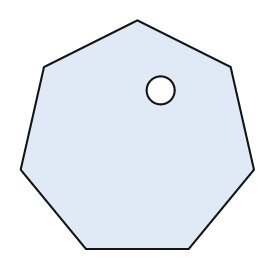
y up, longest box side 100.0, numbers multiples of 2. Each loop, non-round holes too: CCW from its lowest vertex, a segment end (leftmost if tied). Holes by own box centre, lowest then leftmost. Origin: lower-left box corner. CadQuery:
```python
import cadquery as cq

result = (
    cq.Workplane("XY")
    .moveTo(28.0, 0.0)
    .lineTo(72.0, 0.0)
    .lineTo(100.0, 34.0)
    .lineTo(90.0, 78.0)
    .lineTo(50.0, 98.0)
    .lineTo(10.0, 78.0)
    .lineTo(0.0, 34.0)
    .close()
    .moveTo(60.0, 68.0)
    .circle(6.0)
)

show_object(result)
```